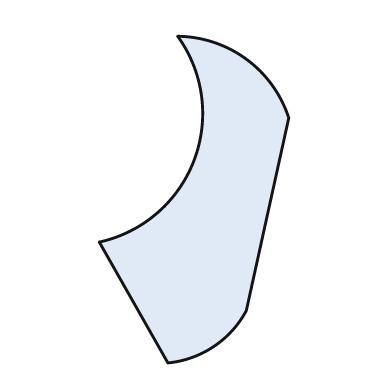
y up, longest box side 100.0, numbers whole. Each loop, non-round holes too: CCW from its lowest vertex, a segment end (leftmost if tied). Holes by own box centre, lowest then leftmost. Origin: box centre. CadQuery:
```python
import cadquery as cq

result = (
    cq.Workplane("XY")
    .moveTo(-8.0, -50.0)
    .threePointArc((6.0, -45.0), (16.0, -34.0))
    .lineTo(29.0, 25.0)
    .threePointArc((16.0, 43.0), (-5.0, 50.0))
    .threePointArc((0.0, 12.0), (-29.0, -13.0))
    .close()
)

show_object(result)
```